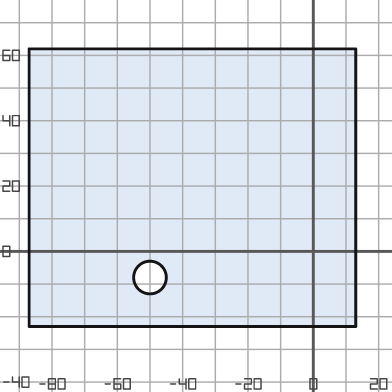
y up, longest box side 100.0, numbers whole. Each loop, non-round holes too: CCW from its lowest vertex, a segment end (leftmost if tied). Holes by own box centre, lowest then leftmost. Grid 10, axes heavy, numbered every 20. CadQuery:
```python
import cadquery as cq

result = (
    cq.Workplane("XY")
    .moveTo(-87.0, -23.0)
    .lineTo(13.0, -23.0)
    .lineTo(13.0, 62.0)
    .lineTo(-87.0, 62.0)
    .close()
    .moveTo(-50.0, -8.0)
    .circle(5.0)
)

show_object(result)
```